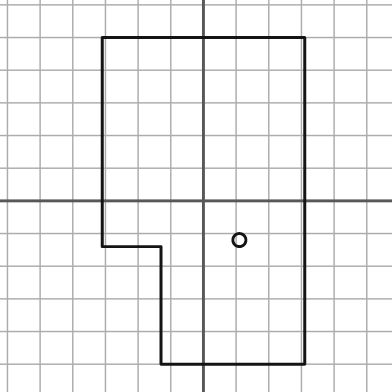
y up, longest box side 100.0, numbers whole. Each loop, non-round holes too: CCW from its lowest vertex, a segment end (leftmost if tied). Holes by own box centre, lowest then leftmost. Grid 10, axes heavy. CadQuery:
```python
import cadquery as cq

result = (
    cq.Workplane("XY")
    .moveTo(-13.0, -50.0)
    .lineTo(31.0, -50.0)
    .lineTo(31.0, 50.0)
    .lineTo(-31.0, 50.0)
    .lineTo(-31.0, -14.0)
    .lineTo(-13.0, -14.0)
    .close()
    .moveTo(11.0, -12.0)
    .circle(2.0)
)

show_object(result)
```